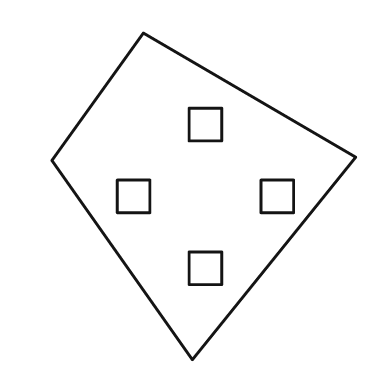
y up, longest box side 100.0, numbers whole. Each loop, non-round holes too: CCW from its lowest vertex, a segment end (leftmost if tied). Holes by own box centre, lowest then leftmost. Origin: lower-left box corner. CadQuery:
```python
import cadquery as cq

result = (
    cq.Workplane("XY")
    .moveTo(43.0, 0.0)
    .lineTo(93.0, 62.0)
    .lineTo(28.0, 100.0)
    .lineTo(0.0, 61.0)
    .close()
    .moveTo(42.0, 23.0)
    .lineTo(52.0, 23.0)
    .lineTo(52.0, 33.0)
    .lineTo(42.0, 33.0)
    .close()
    .moveTo(20.0, 45.0)
    .lineTo(30.0, 45.0)
    .lineTo(30.0, 55.0)
    .lineTo(20.0, 55.0)
    .close()
    .moveTo(64.0, 45.0)
    .lineTo(74.0, 45.0)
    .lineTo(74.0, 55.0)
    .lineTo(64.0, 55.0)
    .close()
    .moveTo(42.0, 67.0)
    .lineTo(52.0, 67.0)
    .lineTo(52.0, 77.0)
    .lineTo(42.0, 77.0)
    .close()
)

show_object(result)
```